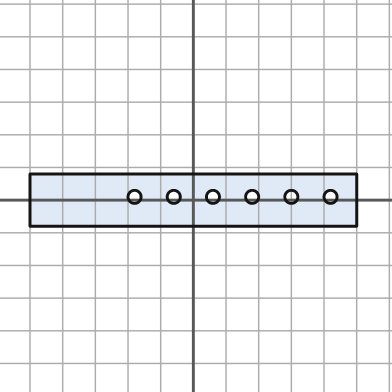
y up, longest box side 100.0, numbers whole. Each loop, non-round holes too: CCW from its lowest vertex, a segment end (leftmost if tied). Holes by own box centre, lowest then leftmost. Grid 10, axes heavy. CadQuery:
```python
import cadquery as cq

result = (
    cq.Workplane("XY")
    .moveTo(-50.0, -8.0)
    .lineTo(50.0, -8.0)
    .lineTo(50.0, 8.0)
    .lineTo(-50.0, 8.0)
    .close()
    .moveTo(-18.0, 1.0)
    .circle(2.0)
    .moveTo(-6.0, 1.0)
    .circle(2.0)
    .moveTo(6.0, 1.0)
    .circle(2.0)
    .moveTo(18.0, 1.0)
    .circle(2.0)
    .moveTo(30.0, 1.0)
    .circle(2.0)
    .moveTo(42.0, 1.0)
    .circle(2.0)
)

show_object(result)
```